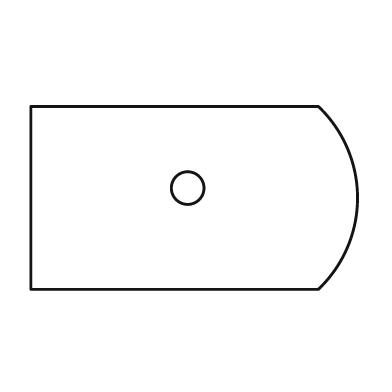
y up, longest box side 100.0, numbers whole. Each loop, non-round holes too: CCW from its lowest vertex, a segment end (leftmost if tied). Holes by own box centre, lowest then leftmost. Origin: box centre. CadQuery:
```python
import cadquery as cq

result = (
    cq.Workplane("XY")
    .moveTo(-50.0, -28.0)
    .lineTo(38.0, -28.0)
    .threePointArc((50.0, 0.0), (38.0, 28.0))
    .lineTo(-50.0, 28.0)
    .close()
    .moveTo(-2.0, 3.0)
    .circle(5.0)
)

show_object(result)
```